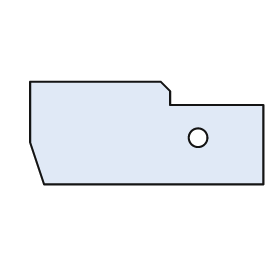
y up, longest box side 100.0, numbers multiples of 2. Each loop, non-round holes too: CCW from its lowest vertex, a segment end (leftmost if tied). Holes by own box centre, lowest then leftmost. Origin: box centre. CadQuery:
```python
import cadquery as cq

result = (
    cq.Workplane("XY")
    .moveTo(-44.0, -22.0)
    .lineTo(50.0, -22.0)
    .lineTo(50.0, 12.0)
    .lineTo(10.0, 12.0)
    .lineTo(10.0, 18.0)
    .lineTo(6.0, 22.0)
    .lineTo(-50.0, 22.0)
    .lineTo(-50.0, -4.0)
    .close()
    .moveTo(22.0, -2.0)
    .circle(4.0)
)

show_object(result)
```